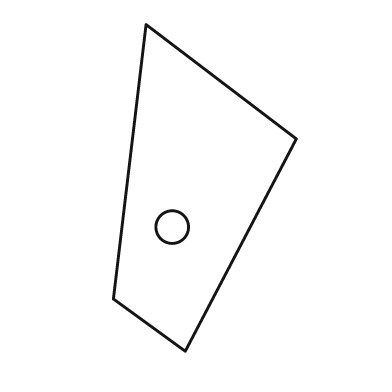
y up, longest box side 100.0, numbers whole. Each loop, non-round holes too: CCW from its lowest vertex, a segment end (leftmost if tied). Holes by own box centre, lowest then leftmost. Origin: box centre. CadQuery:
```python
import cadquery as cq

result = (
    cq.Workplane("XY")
    .moveTo(-6.0, -50.0)
    .lineTo(28.0, 15.0)
    .lineTo(-18.0, 50.0)
    .lineTo(-28.0, -34.0)
    .close()
    .moveTo(-10.0, -12.0)
    .circle(5.0)
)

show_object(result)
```